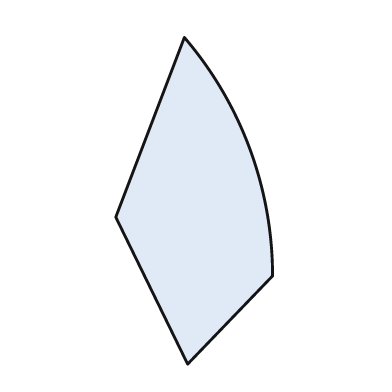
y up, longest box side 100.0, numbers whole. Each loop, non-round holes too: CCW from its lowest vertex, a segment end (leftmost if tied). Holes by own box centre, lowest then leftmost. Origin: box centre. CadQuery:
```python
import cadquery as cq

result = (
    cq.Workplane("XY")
    .moveTo(-2.0, -50.0)
    .lineTo(24.0, -23.0)
    .threePointArc((17.0, 16.0), (-3.0, 50.0))
    .lineTo(-24.0, -5.0)
    .close()
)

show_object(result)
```